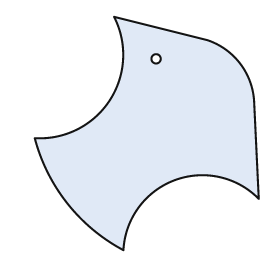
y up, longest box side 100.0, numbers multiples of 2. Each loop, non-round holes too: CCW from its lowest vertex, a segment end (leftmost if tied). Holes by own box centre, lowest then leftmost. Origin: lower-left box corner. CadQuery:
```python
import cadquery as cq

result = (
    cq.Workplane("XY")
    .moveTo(38.0, 0.0)
    .threePointArc((60.0, 30.0), (96.0, 22.0))
    .lineTo(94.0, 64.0)
    .threePointArc((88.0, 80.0), (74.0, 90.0))
    .lineTo(34.0, 100.0)
    .threePointArc((32.0, 64.0), (0.0, 48.0))
    .threePointArc((14.0, 20.0), (38.0, 0.0))
    .close()
    .moveTo(52.0, 82.0)
    .circle(2.0)
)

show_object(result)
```